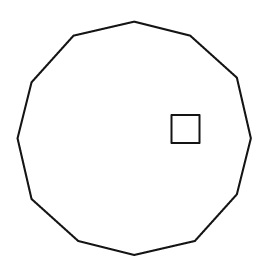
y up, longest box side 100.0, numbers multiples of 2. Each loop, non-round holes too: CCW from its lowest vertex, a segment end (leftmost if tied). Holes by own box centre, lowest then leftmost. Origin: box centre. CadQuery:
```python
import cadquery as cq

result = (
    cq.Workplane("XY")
    .moveTo(0.0, -50.0)
    .lineTo(26.0, -44.0)
    .lineTo(44.0, -24.0)
    .lineTo(50.0, 0.0)
    .lineTo(44.0, 26.0)
    .lineTo(24.0, 44.0)
    .lineTo(0.0, 50.0)
    .lineTo(-26.0, 44.0)
    .lineTo(-44.0, 24.0)
    .lineTo(-50.0, 0.0)
    .lineTo(-44.0, -26.0)
    .lineTo(-24.0, -44.0)
    .close()
    .moveTo(16.0, -2.0)
    .lineTo(28.0, -2.0)
    .lineTo(28.0, 10.0)
    .lineTo(16.0, 10.0)
    .close()
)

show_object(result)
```